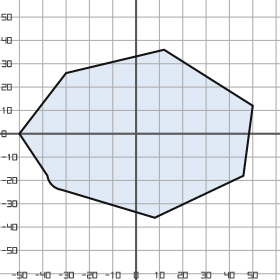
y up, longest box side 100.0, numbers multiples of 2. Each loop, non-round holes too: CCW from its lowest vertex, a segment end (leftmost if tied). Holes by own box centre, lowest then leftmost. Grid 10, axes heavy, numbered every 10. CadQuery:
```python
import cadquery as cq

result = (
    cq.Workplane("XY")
    .moveTo(8.0, -36.0)
    .lineTo(46.0, -18.0)
    .lineTo(50.0, 12.0)
    .lineTo(12.0, 36.0)
    .lineTo(-30.0, 26.0)
    .lineTo(-50.0, 0.0)
    .lineTo(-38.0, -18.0)
    .threePointArc((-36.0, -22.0), (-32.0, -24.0))
    .close()
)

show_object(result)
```